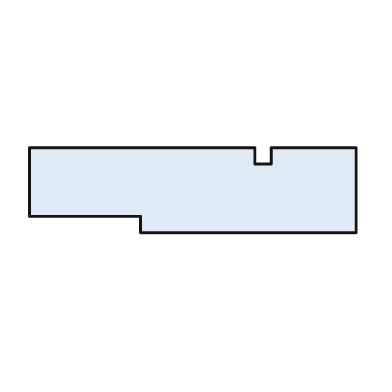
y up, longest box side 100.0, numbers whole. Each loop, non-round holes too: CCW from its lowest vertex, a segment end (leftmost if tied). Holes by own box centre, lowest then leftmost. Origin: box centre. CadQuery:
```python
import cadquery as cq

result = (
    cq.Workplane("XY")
    .moveTo(-16.0, -13.0)
    .lineTo(50.0, -13.0)
    .lineTo(50.0, 13.0)
    .lineTo(24.0, 13.0)
    .lineTo(24.0, 8.0)
    .lineTo(19.0, 8.0)
    .lineTo(19.0, 13.0)
    .lineTo(-50.0, 13.0)
    .lineTo(-50.0, -8.0)
    .lineTo(-16.0, -8.0)
    .close()
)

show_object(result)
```